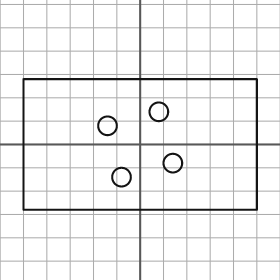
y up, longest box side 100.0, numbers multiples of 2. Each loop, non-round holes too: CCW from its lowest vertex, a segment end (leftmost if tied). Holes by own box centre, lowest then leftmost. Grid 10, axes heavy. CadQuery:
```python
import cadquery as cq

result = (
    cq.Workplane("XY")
    .moveTo(-50.0, -28.0)
    .lineTo(50.0, -28.0)
    .lineTo(50.0, 28.0)
    .lineTo(-50.0, 28.0)
    .close()
    .moveTo(-8.0, -14.0)
    .circle(4.0)
    .moveTo(14.0, -8.0)
    .circle(4.0)
    .moveTo(-14.0, 8.0)
    .circle(4.0)
    .moveTo(8.0, 14.0)
    .circle(4.0)
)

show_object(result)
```